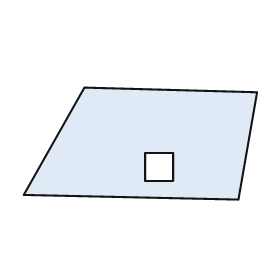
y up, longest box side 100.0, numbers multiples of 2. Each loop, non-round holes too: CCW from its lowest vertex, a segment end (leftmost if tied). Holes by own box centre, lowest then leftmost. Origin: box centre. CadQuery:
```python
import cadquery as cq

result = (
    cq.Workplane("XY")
    .moveTo(42.0, -24.0)
    .lineTo(50.0, 22.0)
    .lineTo(-24.0, 24.0)
    .lineTo(-50.0, -22.0)
    .close()
    .moveTo(2.0, -16.0)
    .lineTo(14.0, -16.0)
    .lineTo(14.0, -4.0)
    .lineTo(2.0, -4.0)
    .close()
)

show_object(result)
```